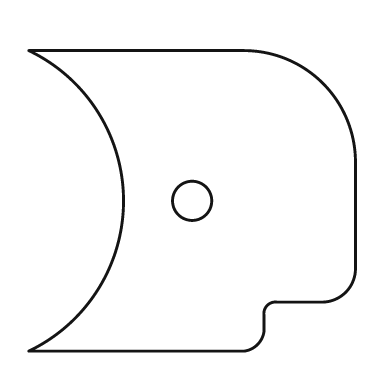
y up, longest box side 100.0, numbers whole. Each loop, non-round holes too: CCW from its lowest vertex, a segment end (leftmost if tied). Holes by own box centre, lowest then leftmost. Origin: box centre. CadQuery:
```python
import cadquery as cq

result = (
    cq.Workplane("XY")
    .moveTo(-50.0, -46.0)
    .lineTo(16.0, -46.0)
    .threePointArc((20.0, -44.0), (22.0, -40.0))
    .lineTo(22.0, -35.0)
    .threePointArc((23.0, -32.0), (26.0, -31.0))
    .lineTo(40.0, -31.0)
    .threePointArc((47.0, -28.0), (50.0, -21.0))
    .lineTo(50.0, 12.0)
    .threePointArc((40.0, 36.0), (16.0, 46.0))
    .lineTo(-50.0, 46.0)
    .threePointArc((-21.0, 0.0), (-50.0, -46.0))
    .close()
    .moveTo(0.0, 0.0)
    .circle(6.0)
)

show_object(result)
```